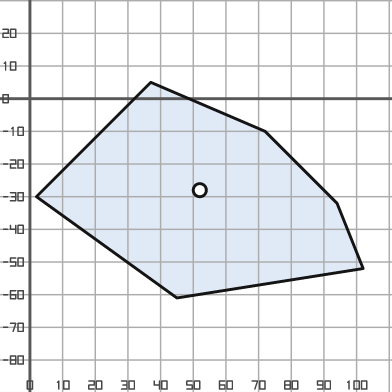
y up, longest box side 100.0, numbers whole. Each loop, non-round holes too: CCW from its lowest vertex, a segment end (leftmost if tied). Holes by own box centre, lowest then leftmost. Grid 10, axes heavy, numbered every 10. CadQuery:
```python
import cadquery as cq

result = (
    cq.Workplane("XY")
    .moveTo(45.0, -61.0)
    .lineTo(102.0, -52.0)
    .lineTo(94.0, -32.0)
    .lineTo(72.0, -10.0)
    .lineTo(37.0, 5.0)
    .lineTo(2.0, -30.0)
    .close()
    .moveTo(52.0, -28.0)
    .circle(2.0)
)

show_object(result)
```